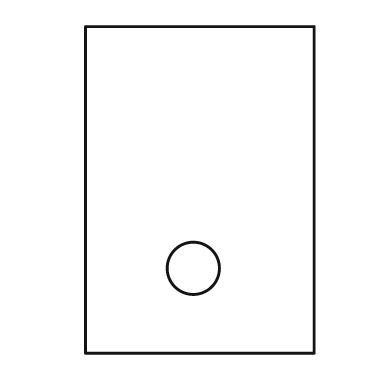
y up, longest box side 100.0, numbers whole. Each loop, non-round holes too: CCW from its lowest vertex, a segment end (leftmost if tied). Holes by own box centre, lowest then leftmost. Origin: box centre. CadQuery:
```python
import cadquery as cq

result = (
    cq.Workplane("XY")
    .moveTo(-35.0, -50.0)
    .lineTo(35.0, -50.0)
    .lineTo(35.0, 50.0)
    .lineTo(-35.0, 50.0)
    .close()
    .moveTo(-2.0, -24.0)
    .circle(8.0)
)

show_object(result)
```